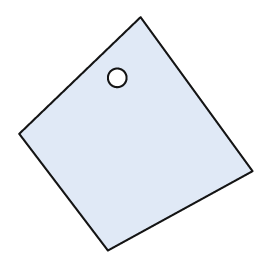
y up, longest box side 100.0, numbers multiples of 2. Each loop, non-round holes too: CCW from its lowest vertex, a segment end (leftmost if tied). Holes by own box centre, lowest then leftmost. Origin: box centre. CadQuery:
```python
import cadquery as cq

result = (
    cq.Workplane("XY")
    .moveTo(-12.0, -50.0)
    .lineTo(50.0, -16.0)
    .lineTo(2.0, 50.0)
    .lineTo(-50.0, 0.0)
    .close()
    .moveTo(-8.0, 24.0)
    .circle(4.0)
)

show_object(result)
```